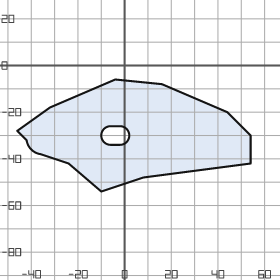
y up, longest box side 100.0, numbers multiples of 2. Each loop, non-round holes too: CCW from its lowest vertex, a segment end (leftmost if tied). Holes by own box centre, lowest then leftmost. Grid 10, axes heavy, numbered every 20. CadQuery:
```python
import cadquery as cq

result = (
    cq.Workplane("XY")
    .moveTo(-10.0, -54.0)
    .lineTo(8.0, -48.0)
    .lineTo(54.0, -42.0)
    .lineTo(54.0, -30.0)
    .lineTo(44.0, -20.0)
    .lineTo(16.0, -8.0)
    .lineTo(-4.0, -6.0)
    .lineTo(-32.0, -18.0)
    .lineTo(-46.0, -28.0)
    .lineTo(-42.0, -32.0)
    .threePointArc((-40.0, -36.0), (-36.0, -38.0))
    .lineTo(-24.0, -42.0)
    .close()
    .moveTo(-6.0, -34.0)
    .lineTo(-2.0, -34.0)
    .threePointArc((2.0, -30.0), (-2.0, -26.0))
    .lineTo(-6.0, -26.0)
    .threePointArc((-10.0, -30.0), (-6.0, -34.0))
    .close()
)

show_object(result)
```